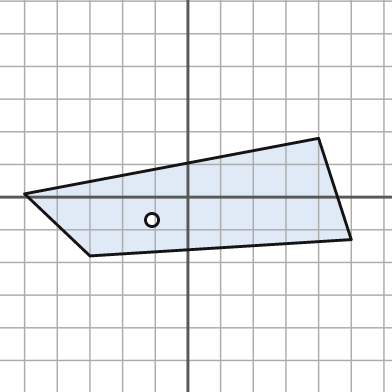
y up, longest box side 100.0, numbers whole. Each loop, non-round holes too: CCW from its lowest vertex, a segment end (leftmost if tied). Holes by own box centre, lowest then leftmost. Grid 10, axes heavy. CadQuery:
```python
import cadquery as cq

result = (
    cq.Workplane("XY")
    .moveTo(-30.0, -18.0)
    .lineTo(50.0, -13.0)
    .lineTo(40.0, 18.0)
    .lineTo(-50.0, 1.0)
    .close()
    .moveTo(-11.0, -7.0)
    .circle(2.0)
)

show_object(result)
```